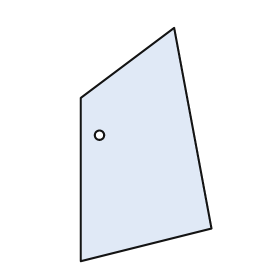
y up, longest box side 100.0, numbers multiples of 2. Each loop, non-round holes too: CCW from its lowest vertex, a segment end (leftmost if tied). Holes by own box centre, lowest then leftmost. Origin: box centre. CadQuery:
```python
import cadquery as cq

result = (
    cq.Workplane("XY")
    .moveTo(-28.0, -50.0)
    .lineTo(28.0, -36.0)
    .lineTo(12.0, 50.0)
    .lineTo(-28.0, 20.0)
    .close()
    .moveTo(-20.0, 4.0)
    .circle(2.0)
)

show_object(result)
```